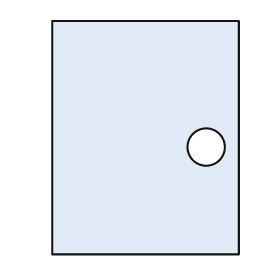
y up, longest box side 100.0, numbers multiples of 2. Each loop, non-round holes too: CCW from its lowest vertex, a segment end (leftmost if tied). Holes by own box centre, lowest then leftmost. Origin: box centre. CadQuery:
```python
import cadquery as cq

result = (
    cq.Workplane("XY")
    .moveTo(-40.0, -50.0)
    .lineTo(40.0, -50.0)
    .lineTo(40.0, 50.0)
    .lineTo(-40.0, 50.0)
    .close()
    .moveTo(26.0, -4.0)
    .circle(8.0)
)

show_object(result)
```